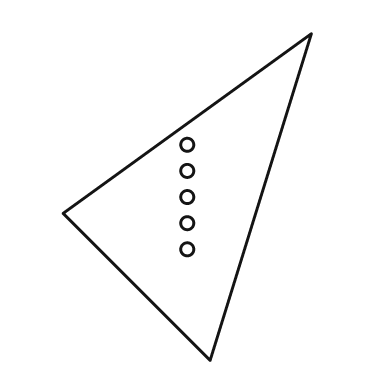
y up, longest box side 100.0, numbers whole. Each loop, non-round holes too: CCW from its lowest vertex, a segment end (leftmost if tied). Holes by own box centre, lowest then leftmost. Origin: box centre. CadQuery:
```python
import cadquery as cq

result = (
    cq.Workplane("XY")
    .moveTo(7.0, -50.0)
    .lineTo(38.0, 50.0)
    .lineTo(-38.0, -5.0)
    .close()
    .moveTo(0.0, -16.0)
    .circle(2.0)
    .moveTo(0.0, -8.0)
    .circle(2.0)
    .moveTo(0.0, 0.0)
    .circle(2.0)
    .moveTo(0.0, 8.0)
    .circle(2.0)
    .moveTo(0.0, 16.0)
    .circle(2.0)
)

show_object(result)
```